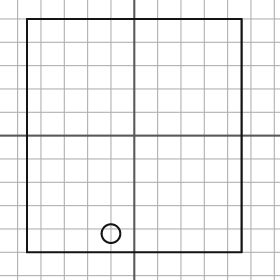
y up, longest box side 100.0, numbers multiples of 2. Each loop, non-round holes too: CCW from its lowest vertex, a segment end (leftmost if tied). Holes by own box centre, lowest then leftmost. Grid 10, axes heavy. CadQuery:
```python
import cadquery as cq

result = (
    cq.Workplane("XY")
    .moveTo(-46.0, -50.0)
    .lineTo(46.0, -50.0)
    .lineTo(46.0, 50.0)
    .lineTo(-46.0, 50.0)
    .close()
    .moveTo(-10.0, -42.0)
    .circle(4.0)
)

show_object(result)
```